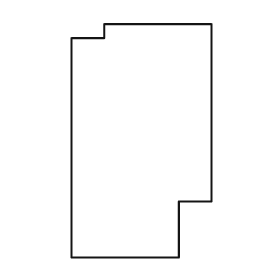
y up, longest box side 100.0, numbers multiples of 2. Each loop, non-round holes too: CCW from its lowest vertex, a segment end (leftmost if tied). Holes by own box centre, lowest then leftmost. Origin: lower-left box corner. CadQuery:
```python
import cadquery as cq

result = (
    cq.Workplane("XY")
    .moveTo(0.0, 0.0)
    .lineTo(46.0, 0.0)
    .lineTo(46.0, 24.0)
    .lineTo(60.0, 24.0)
    .lineTo(60.0, 100.0)
    .lineTo(14.0, 100.0)
    .lineTo(14.0, 94.0)
    .lineTo(0.0, 94.0)
    .close()
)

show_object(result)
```